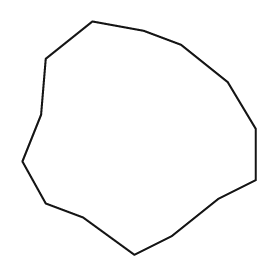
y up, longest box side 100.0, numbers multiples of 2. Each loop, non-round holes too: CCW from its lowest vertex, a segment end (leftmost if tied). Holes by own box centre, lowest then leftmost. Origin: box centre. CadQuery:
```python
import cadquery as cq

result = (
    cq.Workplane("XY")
    .moveTo(-2.0, -50.0)
    .lineTo(14.0, -42.0)
    .lineTo(34.0, -26.0)
    .lineTo(50.0, -18.0)
    .lineTo(50.0, 4.0)
    .lineTo(38.0, 24.0)
    .lineTo(18.0, 40.0)
    .lineTo(2.0, 46.0)
    .lineTo(-20.0, 50.0)
    .lineTo(-40.0, 34.0)
    .lineTo(-42.0, 10.0)
    .lineTo(-50.0, -10.0)
    .lineTo(-40.0, -28.0)
    .lineTo(-24.0, -34.0)
    .close()
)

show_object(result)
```